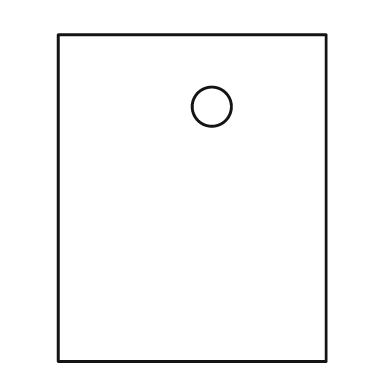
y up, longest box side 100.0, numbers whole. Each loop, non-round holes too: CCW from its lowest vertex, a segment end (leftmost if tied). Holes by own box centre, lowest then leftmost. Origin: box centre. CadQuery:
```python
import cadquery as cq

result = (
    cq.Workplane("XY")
    .moveTo(-41.0, -50.0)
    .lineTo(41.0, -50.0)
    .lineTo(41.0, 50.0)
    .lineTo(-41.0, 50.0)
    .close()
    .moveTo(6.0, 28.0)
    .circle(6.0)
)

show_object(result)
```